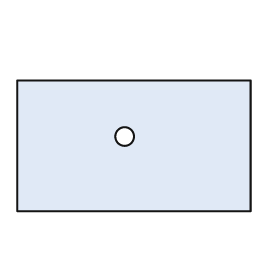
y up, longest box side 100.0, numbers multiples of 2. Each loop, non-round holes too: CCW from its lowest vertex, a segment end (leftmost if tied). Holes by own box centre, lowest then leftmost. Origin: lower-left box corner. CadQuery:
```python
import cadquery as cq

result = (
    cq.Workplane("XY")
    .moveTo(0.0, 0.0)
    .lineTo(100.0, 0.0)
    .lineTo(100.0, 56.0)
    .lineTo(0.0, 56.0)
    .close()
    .moveTo(46.0, 32.0)
    .circle(4.0)
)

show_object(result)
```